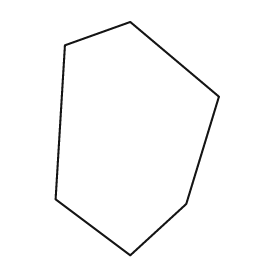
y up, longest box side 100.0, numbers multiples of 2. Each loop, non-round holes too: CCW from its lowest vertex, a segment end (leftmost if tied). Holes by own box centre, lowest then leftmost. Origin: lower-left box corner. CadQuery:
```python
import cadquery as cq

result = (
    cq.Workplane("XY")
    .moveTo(32.0, 0.0)
    .lineTo(56.0, 22.0)
    .lineTo(70.0, 68.0)
    .lineTo(32.0, 100.0)
    .lineTo(4.0, 90.0)
    .lineTo(0.0, 24.0)
    .close()
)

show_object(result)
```